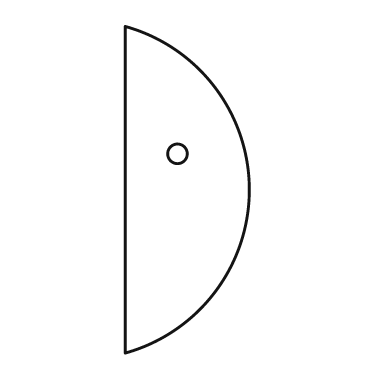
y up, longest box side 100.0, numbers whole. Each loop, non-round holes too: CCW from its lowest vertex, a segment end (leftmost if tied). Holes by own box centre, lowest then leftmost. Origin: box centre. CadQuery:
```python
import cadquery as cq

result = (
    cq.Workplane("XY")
    .moveTo(-19.0, -50.0)
    .threePointArc((19.0, 0.0), (-19.0, 50.0))
    .close()
    .moveTo(-3.0, 11.0)
    .circle(3.0)
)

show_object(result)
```